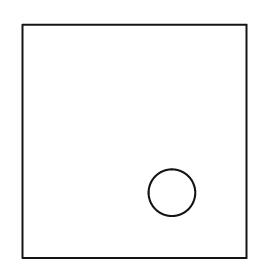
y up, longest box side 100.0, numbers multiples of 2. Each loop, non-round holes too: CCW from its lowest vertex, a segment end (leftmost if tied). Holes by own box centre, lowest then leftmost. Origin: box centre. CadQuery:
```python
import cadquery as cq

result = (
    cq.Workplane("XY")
    .moveTo(-48.0, -50.0)
    .lineTo(48.0, -50.0)
    .lineTo(48.0, 50.0)
    .lineTo(-48.0, 50.0)
    .close()
    .moveTo(16.0, -22.0)
    .circle(10.0)
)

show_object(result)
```